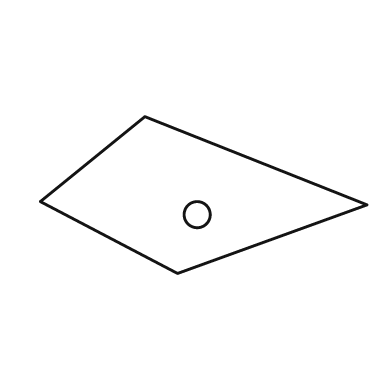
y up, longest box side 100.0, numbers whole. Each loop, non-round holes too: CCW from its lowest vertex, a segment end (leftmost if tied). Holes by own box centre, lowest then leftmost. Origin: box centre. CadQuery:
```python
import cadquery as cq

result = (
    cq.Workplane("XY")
    .moveTo(-8.0, -24.0)
    .lineTo(50.0, -3.0)
    .lineTo(-18.0, 24.0)
    .lineTo(-50.0, -2.0)
    .close()
    .moveTo(-2.0, -6.0)
    .circle(4.0)
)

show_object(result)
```